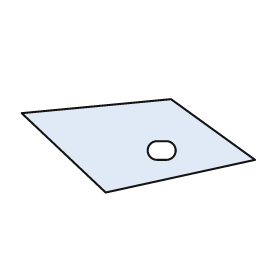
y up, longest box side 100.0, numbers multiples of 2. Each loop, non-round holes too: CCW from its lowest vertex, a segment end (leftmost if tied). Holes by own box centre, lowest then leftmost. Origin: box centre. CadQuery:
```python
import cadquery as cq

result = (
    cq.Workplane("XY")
    .moveTo(-14.0, -20.0)
    .lineTo(50.0, -6.0)
    .lineTo(14.0, 20.0)
    .lineTo(-50.0, 14.0)
    .close()
    .moveTo(8.0, -6.0)
    .lineTo(12.0, -6.0)
    .threePointArc((16.0, -2.0), (12.0, 2.0))
    .lineTo(8.0, 2.0)
    .threePointArc((4.0, -2.0), (8.0, -6.0))
    .close()
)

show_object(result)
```